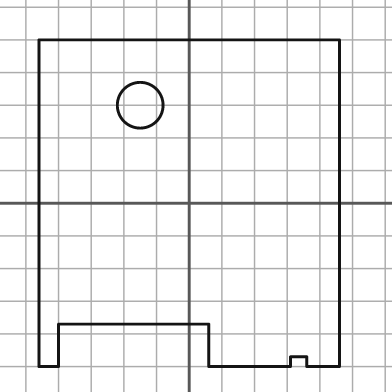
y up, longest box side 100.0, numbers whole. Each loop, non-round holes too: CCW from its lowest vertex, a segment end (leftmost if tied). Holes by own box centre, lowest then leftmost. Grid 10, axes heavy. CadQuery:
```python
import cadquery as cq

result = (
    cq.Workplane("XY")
    .moveTo(-46.0, -50.0)
    .lineTo(-40.0, -50.0)
    .lineTo(-40.0, -37.0)
    .lineTo(6.0, -37.0)
    .lineTo(6.0, -50.0)
    .lineTo(31.0, -50.0)
    .lineTo(31.0, -47.0)
    .lineTo(36.0, -47.0)
    .lineTo(36.0, -50.0)
    .lineTo(46.0, -50.0)
    .lineTo(46.0, 50.0)
    .lineTo(-46.0, 50.0)
    .close()
    .moveTo(-15.0, 30.0)
    .circle(7.0)
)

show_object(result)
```